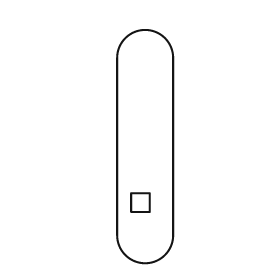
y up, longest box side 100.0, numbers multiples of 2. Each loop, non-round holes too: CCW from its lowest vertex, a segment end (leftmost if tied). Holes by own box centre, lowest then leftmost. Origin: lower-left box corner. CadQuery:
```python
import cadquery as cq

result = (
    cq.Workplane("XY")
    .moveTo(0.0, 12.0)
    .threePointArc((12.0, 0.0), (24.0, 12.0))
    .lineTo(24.0, 88.0)
    .threePointArc((12.0, 100.0), (0.0, 88.0))
    .close()
    .moveTo(6.0, 22.0)
    .lineTo(14.0, 22.0)
    .lineTo(14.0, 30.0)
    .lineTo(6.0, 30.0)
    .close()
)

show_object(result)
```